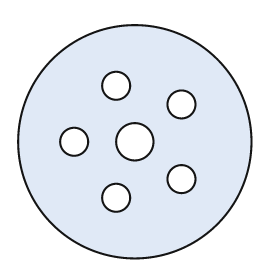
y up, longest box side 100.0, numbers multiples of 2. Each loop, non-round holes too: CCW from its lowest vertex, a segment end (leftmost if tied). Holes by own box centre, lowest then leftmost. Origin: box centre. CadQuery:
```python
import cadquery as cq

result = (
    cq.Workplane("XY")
    .moveTo(0.0, 0.0)
    .circle(50.0)
    .moveTo(-8.0, -24.0)
    .circle(6.0)
    .moveTo(20.0, -16.0)
    .circle(6.0)
    .moveTo(-26.0, 0.0)
    .circle(6.0)
    .moveTo(0.0, 0.0)
    .circle(8.0)
    .moveTo(20.0, 16.0)
    .circle(6.0)
    .moveTo(-8.0, 24.0)
    .circle(6.0)
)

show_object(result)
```